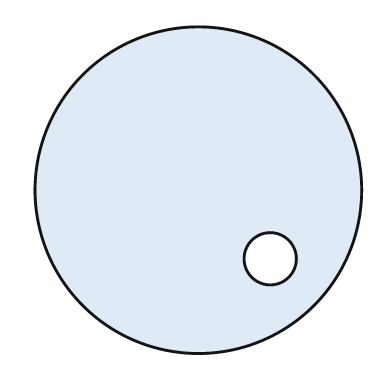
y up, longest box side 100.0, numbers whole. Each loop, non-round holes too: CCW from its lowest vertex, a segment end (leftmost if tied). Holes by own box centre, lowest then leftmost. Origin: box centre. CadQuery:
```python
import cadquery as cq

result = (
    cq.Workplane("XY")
    .moveTo(0.0, 0.0)
    .circle(50.0)
    .moveTo(22.0, -21.0)
    .circle(8.0)
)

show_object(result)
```